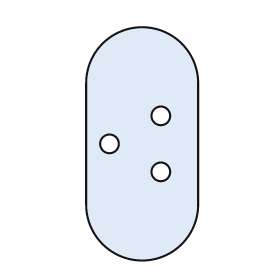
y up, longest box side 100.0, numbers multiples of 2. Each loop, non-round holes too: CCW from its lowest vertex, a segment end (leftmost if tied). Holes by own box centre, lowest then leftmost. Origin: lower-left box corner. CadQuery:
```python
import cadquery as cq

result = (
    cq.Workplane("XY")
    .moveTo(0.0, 24.0)
    .threePointArc((24.0, 0.0), (48.0, 24.0))
    .lineTo(48.0, 76.0)
    .threePointArc((24.0, 100.0), (0.0, 76.0))
    .close()
    .moveTo(32.0, 38.0)
    .circle(4.0)
    .moveTo(10.0, 50.0)
    .circle(4.0)
    .moveTo(32.0, 62.0)
    .circle(4.0)
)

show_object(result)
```